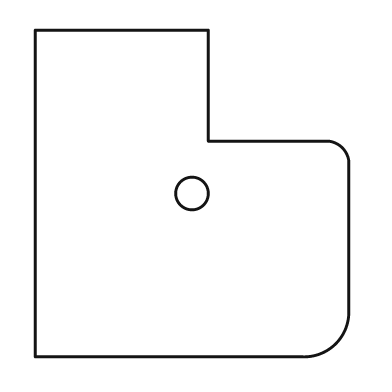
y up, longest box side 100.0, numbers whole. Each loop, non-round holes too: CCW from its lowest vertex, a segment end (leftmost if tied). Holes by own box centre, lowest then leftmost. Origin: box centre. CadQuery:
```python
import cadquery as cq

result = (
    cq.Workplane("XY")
    .moveTo(-48.0, -50.0)
    .lineTo(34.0, -50.0)
    .threePointArc((44.0, -46.0), (48.0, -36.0))
    .lineTo(48.0, 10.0)
    .threePointArc((46.0, 14.0), (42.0, 16.0))
    .lineTo(5.0, 16.0)
    .lineTo(5.0, 50.0)
    .lineTo(-48.0, 50.0)
    .close()
    .moveTo(0.0, 0.0)
    .circle(5.0)
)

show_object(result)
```